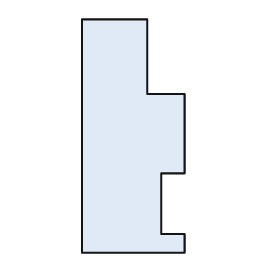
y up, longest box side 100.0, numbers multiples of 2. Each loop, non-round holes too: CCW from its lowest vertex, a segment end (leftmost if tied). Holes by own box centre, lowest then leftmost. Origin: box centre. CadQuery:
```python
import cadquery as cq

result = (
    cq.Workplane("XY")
    .moveTo(-22.0, -50.0)
    .lineTo(22.0, -50.0)
    .lineTo(22.0, -42.0)
    .lineTo(12.0, -42.0)
    .lineTo(12.0, -16.0)
    .lineTo(22.0, -16.0)
    .lineTo(22.0, 18.0)
    .lineTo(6.0, 18.0)
    .lineTo(6.0, 50.0)
    .lineTo(-22.0, 50.0)
    .close()
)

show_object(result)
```